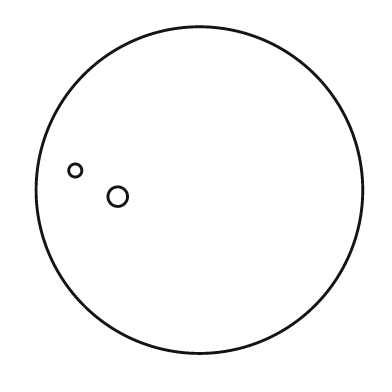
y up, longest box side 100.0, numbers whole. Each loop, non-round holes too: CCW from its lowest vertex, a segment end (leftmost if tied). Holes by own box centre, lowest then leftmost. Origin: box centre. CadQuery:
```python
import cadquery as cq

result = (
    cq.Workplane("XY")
    .moveTo(0.0, 0.0)
    .circle(50.0)
    .moveTo(-25.0, -2.0)
    .circle(3.0)
    .moveTo(-38.0, 6.0)
    .circle(2.0)
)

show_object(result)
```